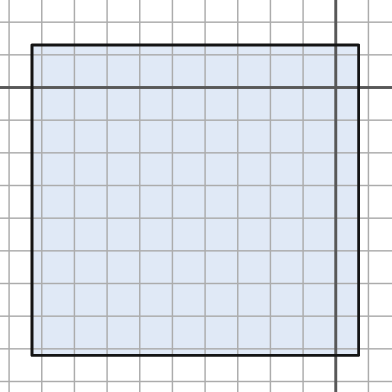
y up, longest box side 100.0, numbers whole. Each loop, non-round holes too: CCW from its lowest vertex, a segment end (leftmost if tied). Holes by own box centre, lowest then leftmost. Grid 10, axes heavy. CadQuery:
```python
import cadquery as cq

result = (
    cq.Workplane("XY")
    .moveTo(-93.0, -82.0)
    .lineTo(7.0, -82.0)
    .lineTo(7.0, 13.0)
    .lineTo(-93.0, 13.0)
    .close()
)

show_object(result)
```